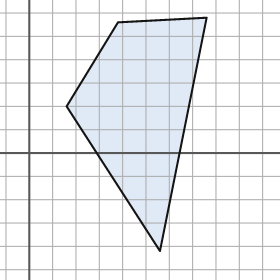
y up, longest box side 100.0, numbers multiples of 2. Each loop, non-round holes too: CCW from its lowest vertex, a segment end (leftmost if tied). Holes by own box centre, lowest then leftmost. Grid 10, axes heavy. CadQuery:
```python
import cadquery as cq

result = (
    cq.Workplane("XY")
    .moveTo(56.0, -42.0)
    .lineTo(76.0, 58.0)
    .lineTo(38.0, 56.0)
    .lineTo(16.0, 20.0)
    .close()
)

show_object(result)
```